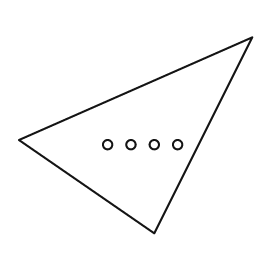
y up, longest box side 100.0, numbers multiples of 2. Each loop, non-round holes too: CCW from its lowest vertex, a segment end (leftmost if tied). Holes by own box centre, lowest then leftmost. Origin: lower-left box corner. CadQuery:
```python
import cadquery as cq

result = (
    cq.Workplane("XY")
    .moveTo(58.0, 0.0)
    .lineTo(100.0, 84.0)
    .lineTo(0.0, 40.0)
    .close()
    .moveTo(38.0, 38.0)
    .circle(2.0)
    .moveTo(48.0, 38.0)
    .circle(2.0)
    .moveTo(58.0, 38.0)
    .circle(2.0)
    .moveTo(68.0, 38.0)
    .circle(2.0)
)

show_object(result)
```